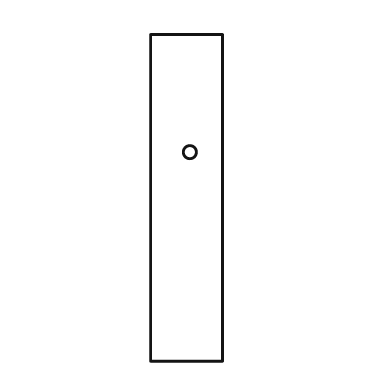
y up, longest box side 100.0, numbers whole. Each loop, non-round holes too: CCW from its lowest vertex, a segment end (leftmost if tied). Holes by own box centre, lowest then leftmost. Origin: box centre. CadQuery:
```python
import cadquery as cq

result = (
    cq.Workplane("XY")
    .moveTo(-11.0, -50.0)
    .lineTo(11.0, -50.0)
    .lineTo(11.0, 50.0)
    .lineTo(-11.0, 50.0)
    .close()
    .moveTo(1.0, 14.0)
    .circle(2.0)
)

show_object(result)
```